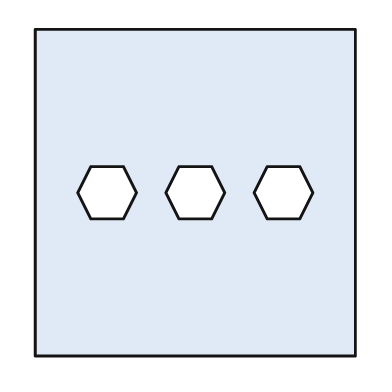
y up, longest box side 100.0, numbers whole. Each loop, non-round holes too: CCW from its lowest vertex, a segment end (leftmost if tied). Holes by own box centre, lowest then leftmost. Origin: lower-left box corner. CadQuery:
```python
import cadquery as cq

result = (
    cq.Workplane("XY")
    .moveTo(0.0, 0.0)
    .lineTo(98.0, 0.0)
    .lineTo(98.0, 100.0)
    .lineTo(0.0, 100.0)
    .close()
    .moveTo(17.0, 42.0)
    .lineTo(27.0, 42.0)
    .lineTo(31.0, 50.0)
    .lineTo(27.0, 58.0)
    .lineTo(17.0, 58.0)
    .lineTo(13.0, 50.0)
    .close()
    .moveTo(44.0, 42.0)
    .lineTo(54.0, 42.0)
    .lineTo(58.0, 50.0)
    .lineTo(54.0, 58.0)
    .lineTo(44.0, 58.0)
    .lineTo(40.0, 50.0)
    .close()
    .moveTo(71.0, 42.0)
    .lineTo(81.0, 42.0)
    .lineTo(85.0, 50.0)
    .lineTo(81.0, 58.0)
    .lineTo(71.0, 58.0)
    .lineTo(67.0, 50.0)
    .close()
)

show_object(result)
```